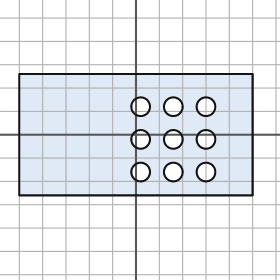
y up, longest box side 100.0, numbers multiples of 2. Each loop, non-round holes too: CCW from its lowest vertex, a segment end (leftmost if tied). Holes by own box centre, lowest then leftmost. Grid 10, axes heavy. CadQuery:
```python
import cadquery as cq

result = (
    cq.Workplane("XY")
    .moveTo(-50.0, -26.0)
    .lineTo(50.0, -26.0)
    .lineTo(50.0, 26.0)
    .lineTo(-50.0, 26.0)
    .close()
    .moveTo(2.0, -16.0)
    .circle(4.0)
    .moveTo(16.0, -16.0)
    .circle(4.0)
    .moveTo(30.0, -16.0)
    .circle(4.0)
    .moveTo(2.0, -2.0)
    .circle(4.0)
    .moveTo(16.0, -2.0)
    .circle(4.0)
    .moveTo(30.0, -2.0)
    .circle(4.0)
    .moveTo(2.0, 12.0)
    .circle(4.0)
    .moveTo(16.0, 12.0)
    .circle(4.0)
    .moveTo(30.0, 12.0)
    .circle(4.0)
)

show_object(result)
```